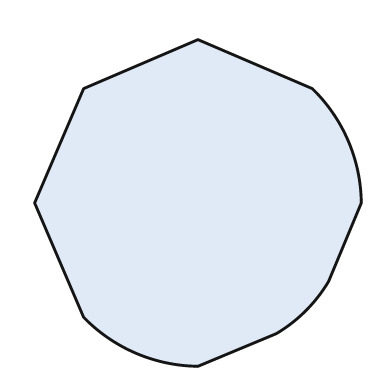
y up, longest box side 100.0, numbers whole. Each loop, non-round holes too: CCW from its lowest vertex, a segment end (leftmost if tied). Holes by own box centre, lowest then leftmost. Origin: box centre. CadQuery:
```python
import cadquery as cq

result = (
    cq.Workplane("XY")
    .moveTo(0.0, -50.0)
    .lineTo(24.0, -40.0)
    .threePointArc((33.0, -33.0), (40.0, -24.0))
    .lineTo(50.0, 0.0)
    .threePointArc((46.0, 19.0), (35.0, 35.0))
    .lineTo(0.0, 50.0)
    .lineTo(-35.0, 35.0)
    .lineTo(-50.0, 0.0)
    .lineTo(-35.0, -35.0)
    .threePointArc((-19.0, -46.0), (0.0, -50.0))
    .close()
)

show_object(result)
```